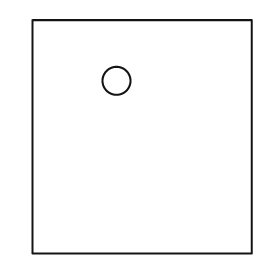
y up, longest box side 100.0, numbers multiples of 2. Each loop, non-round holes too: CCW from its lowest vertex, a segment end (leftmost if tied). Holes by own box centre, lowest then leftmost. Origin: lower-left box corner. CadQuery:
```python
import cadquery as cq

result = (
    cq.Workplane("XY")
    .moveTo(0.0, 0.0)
    .lineTo(94.0, 0.0)
    .lineTo(94.0, 100.0)
    .lineTo(0.0, 100.0)
    .close()
    .moveTo(36.0, 74.0)
    .circle(6.0)
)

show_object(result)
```